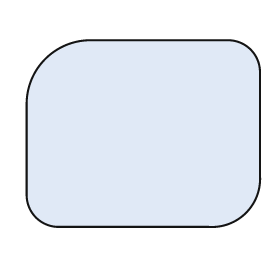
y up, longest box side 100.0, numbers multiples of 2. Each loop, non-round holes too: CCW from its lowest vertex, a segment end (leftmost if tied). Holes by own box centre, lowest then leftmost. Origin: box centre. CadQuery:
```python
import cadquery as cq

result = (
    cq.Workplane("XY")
    .moveTo(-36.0, -40.0)
    .lineTo(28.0, -40.0)
    .threePointArc((44.0, -34.0), (50.0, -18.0))
    .lineTo(50.0, 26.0)
    .threePointArc((46.0, 36.0), (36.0, 40.0))
    .lineTo(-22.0, 40.0)
    .threePointArc((-42.0, 32.0), (-50.0, 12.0))
    .lineTo(-50.0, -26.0)
    .threePointArc((-46.0, -36.0), (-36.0, -40.0))
    .close()
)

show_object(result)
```